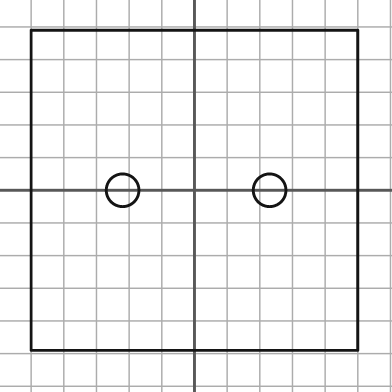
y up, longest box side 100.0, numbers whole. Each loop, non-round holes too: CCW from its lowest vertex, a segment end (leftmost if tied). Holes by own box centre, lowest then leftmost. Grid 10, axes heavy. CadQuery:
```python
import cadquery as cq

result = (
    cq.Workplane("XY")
    .moveTo(-50.0, -49.0)
    .lineTo(50.0, -49.0)
    .lineTo(50.0, 49.0)
    .lineTo(-50.0, 49.0)
    .close()
    .moveTo(-22.0, 0.0)
    .circle(5.0)
    .moveTo(23.0, 0.0)
    .circle(5.0)
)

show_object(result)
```